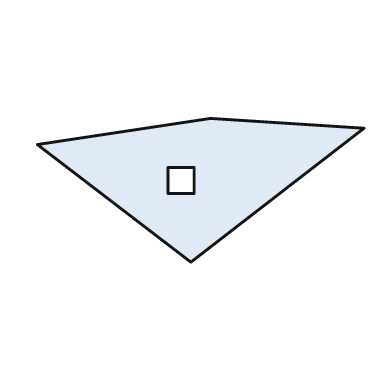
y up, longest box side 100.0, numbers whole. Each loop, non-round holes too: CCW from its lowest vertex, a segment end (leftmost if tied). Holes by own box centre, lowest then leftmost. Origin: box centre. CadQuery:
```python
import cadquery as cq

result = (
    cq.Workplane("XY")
    .moveTo(-3.0, -22.0)
    .lineTo(50.0, 19.0)
    .lineTo(3.0, 22.0)
    .lineTo(-50.0, 14.0)
    .close()
    .moveTo(-10.0, -1.0)
    .lineTo(-2.0, -1.0)
    .lineTo(-2.0, 7.0)
    .lineTo(-10.0, 7.0)
    .close()
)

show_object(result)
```